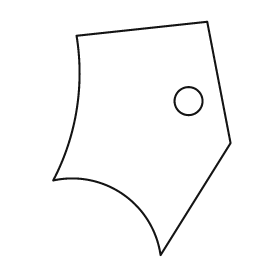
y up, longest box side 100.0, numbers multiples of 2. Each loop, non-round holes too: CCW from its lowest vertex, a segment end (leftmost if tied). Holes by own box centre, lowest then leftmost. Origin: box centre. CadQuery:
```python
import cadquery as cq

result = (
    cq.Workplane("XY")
    .moveTo(8.0, -50.0)
    .lineTo(38.0, -2.0)
    .lineTo(28.0, 50.0)
    .lineTo(-28.0, 44.0)
    .threePointArc((-28.0, 12.0), (-38.0, -18.0))
    .threePointArc((-8.0, -24.0), (8.0, -50.0))
    .close()
    .moveTo(20.0, 16.0)
    .circle(6.0)
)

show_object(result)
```